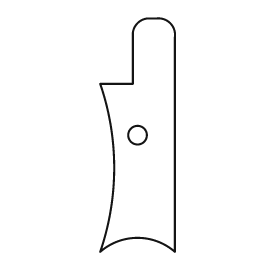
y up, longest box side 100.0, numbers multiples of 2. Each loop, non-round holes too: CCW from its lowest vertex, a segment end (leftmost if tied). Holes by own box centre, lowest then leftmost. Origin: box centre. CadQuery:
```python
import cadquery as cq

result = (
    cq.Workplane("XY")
    .moveTo(-16.0, -50.0)
    .threePointArc((0.0, -44.0), (16.0, -50.0))
    .lineTo(16.0, 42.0)
    .threePointArc((14.0, 48.0), (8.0, 50.0))
    .lineTo(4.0, 50.0)
    .threePointArc((0.0, 48.0), (-2.0, 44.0))
    .lineTo(-2.0, 22.0)
    .lineTo(-16.0, 22.0)
    .threePointArc((-10.0, -14.0), (-16.0, -50.0))
    .close()
    .moveTo(0.0, 0.0)
    .circle(4.0)
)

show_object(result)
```